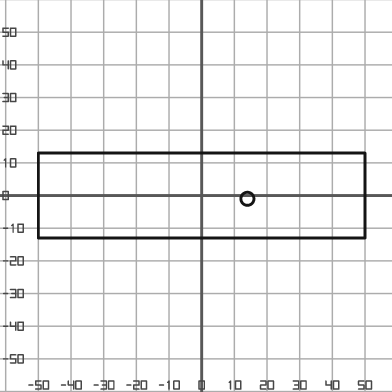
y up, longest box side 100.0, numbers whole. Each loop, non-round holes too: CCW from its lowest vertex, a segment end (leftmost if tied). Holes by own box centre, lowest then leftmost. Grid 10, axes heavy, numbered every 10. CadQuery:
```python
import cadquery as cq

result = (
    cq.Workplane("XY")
    .moveTo(-50.0, -13.0)
    .lineTo(50.0, -13.0)
    .lineTo(50.0, 13.0)
    .lineTo(-50.0, 13.0)
    .close()
    .moveTo(14.0, -1.0)
    .circle(2.0)
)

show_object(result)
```